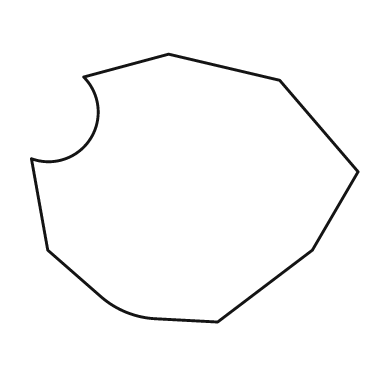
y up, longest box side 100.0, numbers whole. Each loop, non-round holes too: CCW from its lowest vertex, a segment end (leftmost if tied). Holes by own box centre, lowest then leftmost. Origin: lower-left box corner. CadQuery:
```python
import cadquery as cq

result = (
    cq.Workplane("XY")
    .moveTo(57.0, 0.0)
    .lineTo(86.0, 22.0)
    .lineTo(100.0, 46.0)
    .lineTo(76.0, 74.0)
    .lineTo(42.0, 82.0)
    .lineTo(16.0, 75.0)
    .threePointArc((18.0, 56.0), (0.0, 50.0))
    .lineTo(5.0, 22.0)
    .lineTo(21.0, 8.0)
    .threePointArc((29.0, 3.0), (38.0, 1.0))
    .close()
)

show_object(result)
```